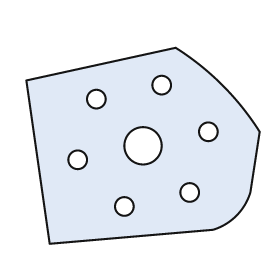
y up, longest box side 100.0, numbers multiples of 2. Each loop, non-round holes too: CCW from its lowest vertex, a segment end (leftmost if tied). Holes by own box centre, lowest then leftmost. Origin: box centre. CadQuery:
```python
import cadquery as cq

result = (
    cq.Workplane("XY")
    .moveTo(-40.0, -42.0)
    .lineTo(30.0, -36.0)
    .threePointArc((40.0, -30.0), (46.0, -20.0))
    .lineTo(50.0, 6.0)
    .threePointArc((34.0, 26.0), (14.0, 42.0))
    .lineTo(-50.0, 28.0)
    .close()
    .moveTo(-8.0, -26.0)
    .circle(4.0)
    .moveTo(20.0, -20.0)
    .circle(4.0)
    .moveTo(-28.0, -6.0)
    .circle(4.0)
    .moveTo(0.0, 0.0)
    .circle(8.0)
    .moveTo(28.0, 6.0)
    .circle(4.0)
    .moveTo(-20.0, 20.0)
    .circle(4.0)
    .moveTo(8.0, 26.0)
    .circle(4.0)
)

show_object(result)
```